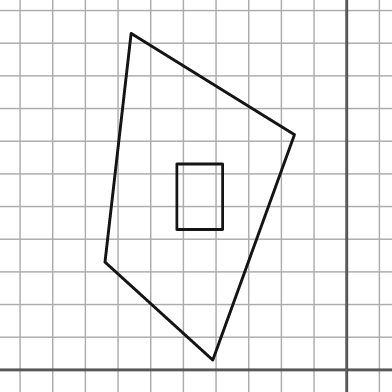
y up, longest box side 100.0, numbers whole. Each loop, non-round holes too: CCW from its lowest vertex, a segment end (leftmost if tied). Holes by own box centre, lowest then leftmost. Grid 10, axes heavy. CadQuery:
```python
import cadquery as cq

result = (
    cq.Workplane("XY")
    .moveTo(-41.0, 3.0)
    .lineTo(-16.0, 72.0)
    .lineTo(-66.0, 103.0)
    .lineTo(-74.0, 33.0)
    .close()
    .moveTo(-52.0, 43.0)
    .lineTo(-38.0, 43.0)
    .lineTo(-38.0, 63.0)
    .lineTo(-52.0, 63.0)
    .close()
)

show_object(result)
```